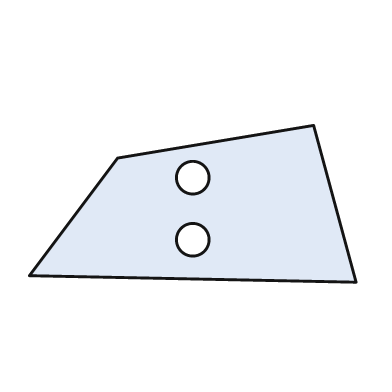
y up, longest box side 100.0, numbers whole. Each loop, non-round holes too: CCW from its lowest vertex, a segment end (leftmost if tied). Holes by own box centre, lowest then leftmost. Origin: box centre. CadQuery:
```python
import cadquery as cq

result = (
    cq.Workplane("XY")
    .moveTo(50.0, -24.0)
    .lineTo(37.0, 24.0)
    .lineTo(-23.0, 14.0)
    .lineTo(-50.0, -22.0)
    .close()
    .moveTo(0.0, -11.0)
    .circle(5.0)
    .moveTo(0.0, 8.0)
    .circle(5.0)
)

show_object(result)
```